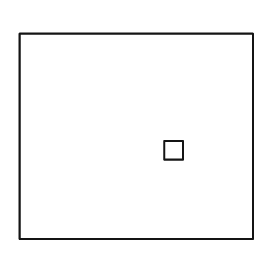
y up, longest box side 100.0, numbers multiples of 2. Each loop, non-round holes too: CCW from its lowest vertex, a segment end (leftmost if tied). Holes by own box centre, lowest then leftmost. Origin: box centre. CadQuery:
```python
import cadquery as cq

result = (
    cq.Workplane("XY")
    .moveTo(-50.0, -44.0)
    .lineTo(50.0, -44.0)
    .lineTo(50.0, 44.0)
    .lineTo(-50.0, 44.0)
    .close()
    .moveTo(12.0, -10.0)
    .lineTo(20.0, -10.0)
    .lineTo(20.0, -2.0)
    .lineTo(12.0, -2.0)
    .close()
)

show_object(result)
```